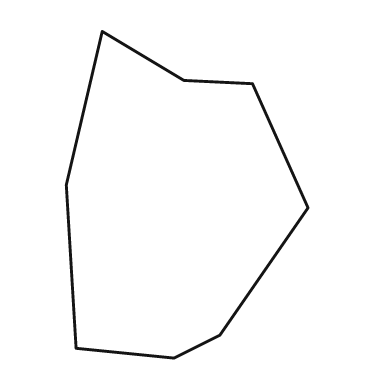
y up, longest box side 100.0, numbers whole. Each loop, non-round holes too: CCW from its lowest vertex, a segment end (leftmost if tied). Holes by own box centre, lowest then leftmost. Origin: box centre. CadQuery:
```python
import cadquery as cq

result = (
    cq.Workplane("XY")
    .moveTo(-4.0, -50.0)
    .lineTo(10.0, -43.0)
    .lineTo(37.0, -4.0)
    .lineTo(20.0, 34.0)
    .lineTo(-1.0, 35.0)
    .lineTo(-26.0, 50.0)
    .lineTo(-37.0, 3.0)
    .lineTo(-34.0, -47.0)
    .close()
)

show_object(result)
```